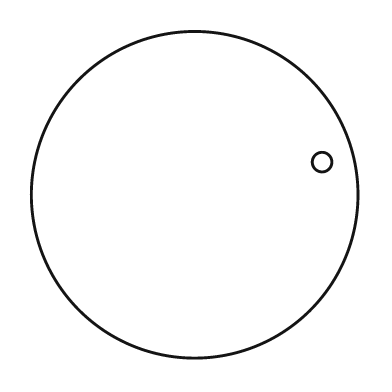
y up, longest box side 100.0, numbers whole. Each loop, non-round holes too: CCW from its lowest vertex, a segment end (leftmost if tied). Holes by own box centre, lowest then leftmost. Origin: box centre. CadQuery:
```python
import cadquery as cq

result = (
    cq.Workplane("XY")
    .moveTo(0.0, 0.0)
    .circle(50.0)
    .moveTo(39.0, 10.0)
    .circle(3.0)
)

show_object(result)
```